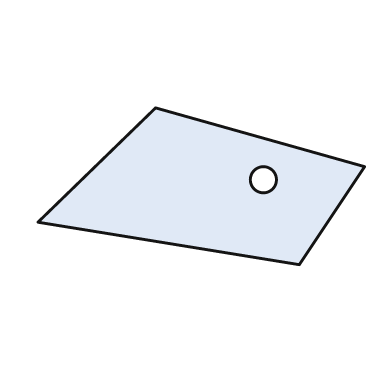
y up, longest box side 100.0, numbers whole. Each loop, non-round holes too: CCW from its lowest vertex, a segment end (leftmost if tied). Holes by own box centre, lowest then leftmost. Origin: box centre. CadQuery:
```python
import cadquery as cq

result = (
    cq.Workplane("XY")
    .moveTo(30.0, -24.0)
    .lineTo(50.0, 6.0)
    .lineTo(-14.0, 24.0)
    .lineTo(-50.0, -11.0)
    .close()
    .moveTo(19.0, 2.0)
    .circle(4.0)
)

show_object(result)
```